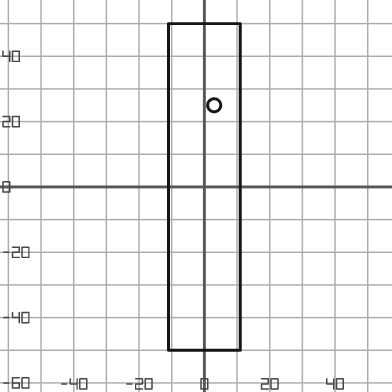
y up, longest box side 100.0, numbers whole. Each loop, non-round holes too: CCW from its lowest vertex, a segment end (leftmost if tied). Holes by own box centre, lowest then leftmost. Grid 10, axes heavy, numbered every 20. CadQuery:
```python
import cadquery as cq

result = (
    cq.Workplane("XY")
    .moveTo(-11.0, -50.0)
    .lineTo(11.0, -50.0)
    .lineTo(11.0, 50.0)
    .lineTo(-11.0, 50.0)
    .close()
    .moveTo(3.0, 25.0)
    .circle(2.0)
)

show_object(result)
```